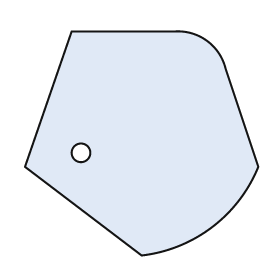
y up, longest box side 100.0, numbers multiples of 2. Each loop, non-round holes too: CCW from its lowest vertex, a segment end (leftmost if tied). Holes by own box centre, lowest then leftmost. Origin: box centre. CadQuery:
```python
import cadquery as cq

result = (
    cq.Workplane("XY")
    .moveTo(0.0, -48.0)
    .threePointArc((30.0, -36.0), (50.0, -10.0))
    .lineTo(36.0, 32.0)
    .threePointArc((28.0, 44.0), (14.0, 48.0))
    .lineTo(-30.0, 48.0)
    .lineTo(-50.0, -10.0)
    .close()
    .moveTo(-26.0, -4.0)
    .circle(4.0)
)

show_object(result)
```